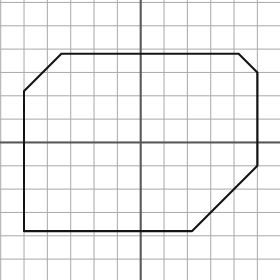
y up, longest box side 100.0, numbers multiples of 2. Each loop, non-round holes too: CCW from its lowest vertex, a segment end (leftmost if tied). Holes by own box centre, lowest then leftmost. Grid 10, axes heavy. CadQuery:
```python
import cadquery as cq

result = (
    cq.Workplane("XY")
    .moveTo(-50.0, -38.0)
    .lineTo(22.0, -38.0)
    .lineTo(50.0, -10.0)
    .lineTo(50.0, 30.0)
    .lineTo(42.0, 38.0)
    .lineTo(-34.0, 38.0)
    .lineTo(-50.0, 22.0)
    .close()
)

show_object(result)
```